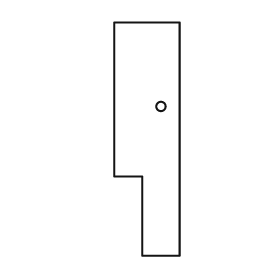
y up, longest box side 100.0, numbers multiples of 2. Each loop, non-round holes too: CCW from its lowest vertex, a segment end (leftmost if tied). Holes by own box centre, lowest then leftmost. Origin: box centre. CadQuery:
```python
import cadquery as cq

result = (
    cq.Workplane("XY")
    .moveTo(-2.0, -50.0)
    .lineTo(14.0, -50.0)
    .lineTo(14.0, 50.0)
    .lineTo(-14.0, 50.0)
    .lineTo(-14.0, -16.0)
    .lineTo(-2.0, -16.0)
    .close()
    .moveTo(6.0, 14.0)
    .circle(2.0)
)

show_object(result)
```